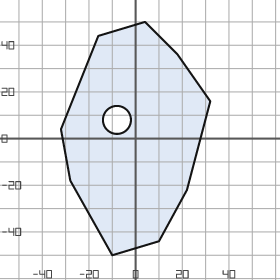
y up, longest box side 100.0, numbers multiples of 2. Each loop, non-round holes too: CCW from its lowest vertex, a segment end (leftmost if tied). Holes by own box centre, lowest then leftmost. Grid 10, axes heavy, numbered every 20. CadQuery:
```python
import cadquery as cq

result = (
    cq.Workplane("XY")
    .moveTo(-10.0, -50.0)
    .lineTo(10.0, -44.0)
    .lineTo(22.0, -22.0)
    .lineTo(32.0, 16.0)
    .lineTo(18.0, 36.0)
    .lineTo(4.0, 50.0)
    .lineTo(-16.0, 44.0)
    .lineTo(-32.0, 4.0)
    .lineTo(-28.0, -18.0)
    .close()
    .moveTo(-8.0, 8.0)
    .circle(6.0)
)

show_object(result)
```